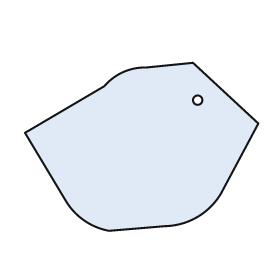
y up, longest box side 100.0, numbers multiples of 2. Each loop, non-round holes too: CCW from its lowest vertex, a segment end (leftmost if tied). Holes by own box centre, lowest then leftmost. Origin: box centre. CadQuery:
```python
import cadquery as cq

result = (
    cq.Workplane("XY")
    .moveTo(-14.0, -36.0)
    .lineTo(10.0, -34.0)
    .threePointArc((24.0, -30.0), (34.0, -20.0))
    .lineTo(50.0, 10.0)
    .lineTo(22.0, 36.0)
    .lineTo(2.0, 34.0)
    .threePointArc((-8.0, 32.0), (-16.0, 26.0))
    .lineTo(-50.0, 6.0)
    .lineTo(-32.0, -24.0)
    .threePointArc((-24.0, -32.0), (-14.0, -36.0))
    .close()
    .moveTo(24.0, 20.0)
    .circle(2.0)
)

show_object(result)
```